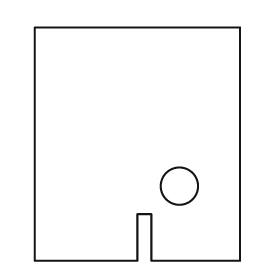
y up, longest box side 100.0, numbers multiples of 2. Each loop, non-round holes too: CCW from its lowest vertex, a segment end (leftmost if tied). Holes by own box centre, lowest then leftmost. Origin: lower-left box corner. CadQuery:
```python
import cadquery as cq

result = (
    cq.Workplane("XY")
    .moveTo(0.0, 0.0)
    .lineTo(44.0, 0.0)
    .lineTo(44.0, 20.0)
    .lineTo(50.0, 20.0)
    .lineTo(50.0, 0.0)
    .lineTo(88.0, 0.0)
    .lineTo(88.0, 100.0)
    .lineTo(0.0, 100.0)
    .close()
    .moveTo(62.0, 32.0)
    .circle(8.0)
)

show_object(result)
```